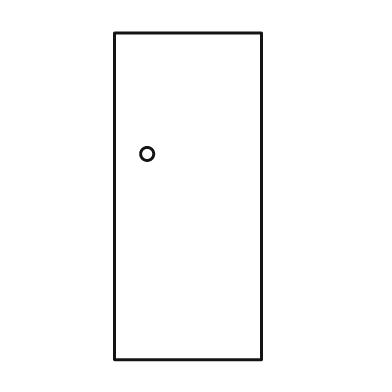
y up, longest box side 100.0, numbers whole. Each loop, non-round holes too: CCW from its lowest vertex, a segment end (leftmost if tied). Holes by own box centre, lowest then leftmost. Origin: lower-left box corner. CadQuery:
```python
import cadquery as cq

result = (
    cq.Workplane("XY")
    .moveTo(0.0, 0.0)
    .lineTo(45.0, 0.0)
    .lineTo(45.0, 100.0)
    .lineTo(0.0, 100.0)
    .close()
    .moveTo(10.0, 63.0)
    .circle(2.0)
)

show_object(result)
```